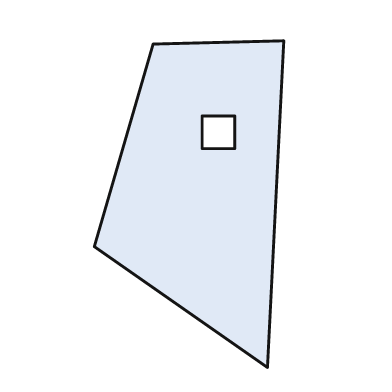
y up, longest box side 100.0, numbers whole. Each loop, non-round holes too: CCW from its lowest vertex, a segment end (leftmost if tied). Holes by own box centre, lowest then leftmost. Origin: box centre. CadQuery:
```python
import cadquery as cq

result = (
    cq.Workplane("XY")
    .moveTo(24.0, -50.0)
    .lineTo(29.0, 50.0)
    .lineTo(-11.0, 49.0)
    .lineTo(-29.0, -13.0)
    .close()
    .moveTo(4.0, 17.0)
    .lineTo(14.0, 17.0)
    .lineTo(14.0, 27.0)
    .lineTo(4.0, 27.0)
    .close()
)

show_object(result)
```